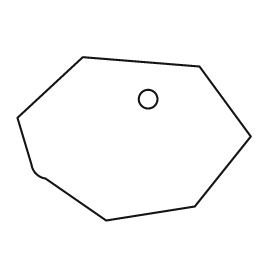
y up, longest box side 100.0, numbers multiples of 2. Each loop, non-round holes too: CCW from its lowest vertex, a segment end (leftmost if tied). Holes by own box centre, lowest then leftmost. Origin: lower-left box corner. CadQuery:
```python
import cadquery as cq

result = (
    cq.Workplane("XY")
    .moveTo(38.0, 0.0)
    .lineTo(76.0, 6.0)
    .lineTo(100.0, 36.0)
    .lineTo(78.0, 66.0)
    .lineTo(28.0, 70.0)
    .lineTo(0.0, 44.0)
    .lineTo(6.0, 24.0)
    .threePointArc((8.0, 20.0), (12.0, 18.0))
    .close()
    .moveTo(56.0, 52.0)
    .circle(4.0)
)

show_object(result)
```